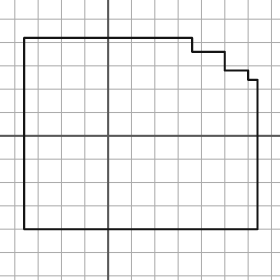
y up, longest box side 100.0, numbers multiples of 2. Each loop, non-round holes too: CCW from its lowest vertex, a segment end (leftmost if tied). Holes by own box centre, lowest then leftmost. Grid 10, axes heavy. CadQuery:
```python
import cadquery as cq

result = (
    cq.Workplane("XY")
    .moveTo(-36.0, -40.0)
    .lineTo(64.0, -40.0)
    .lineTo(64.0, 24.0)
    .lineTo(60.0, 24.0)
    .lineTo(60.0, 28.0)
    .lineTo(50.0, 28.0)
    .lineTo(50.0, 36.0)
    .lineTo(36.0, 36.0)
    .lineTo(36.0, 42.0)
    .lineTo(-36.0, 42.0)
    .close()
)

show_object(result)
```